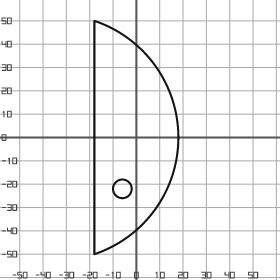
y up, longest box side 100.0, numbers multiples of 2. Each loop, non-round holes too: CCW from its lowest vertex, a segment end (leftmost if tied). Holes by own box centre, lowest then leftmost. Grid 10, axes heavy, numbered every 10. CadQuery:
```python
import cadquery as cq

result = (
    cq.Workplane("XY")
    .moveTo(-18.0, -50.0)
    .threePointArc((18.0, 0.0), (-18.0, 50.0))
    .close()
    .moveTo(-6.0, -22.0)
    .circle(4.0)
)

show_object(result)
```